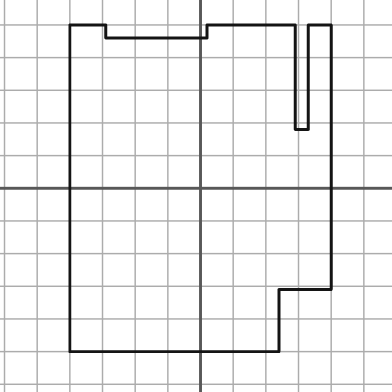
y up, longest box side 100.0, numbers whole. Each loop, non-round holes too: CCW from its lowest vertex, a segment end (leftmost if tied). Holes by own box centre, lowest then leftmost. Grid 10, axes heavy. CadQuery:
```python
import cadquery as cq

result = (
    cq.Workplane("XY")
    .moveTo(-40.0, -50.0)
    .lineTo(24.0, -50.0)
    .lineTo(24.0, -31.0)
    .lineTo(40.0, -31.0)
    .lineTo(40.0, 50.0)
    .lineTo(33.0, 50.0)
    .lineTo(33.0, 18.0)
    .lineTo(29.0, 18.0)
    .lineTo(29.0, 50.0)
    .lineTo(2.0, 50.0)
    .lineTo(2.0, 46.0)
    .lineTo(-29.0, 46.0)
    .lineTo(-29.0, 50.0)
    .lineTo(-40.0, 50.0)
    .close()
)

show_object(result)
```